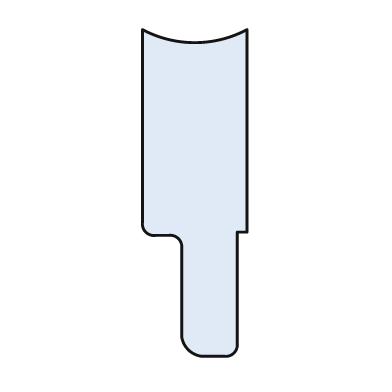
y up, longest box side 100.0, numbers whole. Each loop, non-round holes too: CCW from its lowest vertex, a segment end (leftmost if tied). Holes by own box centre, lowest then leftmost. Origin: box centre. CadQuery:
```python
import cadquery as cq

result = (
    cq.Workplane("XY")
    .moveTo(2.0, -50.0)
    .lineTo(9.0, -50.0)
    .threePointArc((12.0, -49.0), (13.0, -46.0))
    .lineTo(13.0, -12.0)
    .lineTo(16.0, -12.0)
    .lineTo(16.0, 50.0)
    .threePointArc((0.0, 46.0), (-16.0, 50.0))
    .lineTo(-16.0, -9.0)
    .threePointArc((-15.0, -12.0), (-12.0, -13.0))
    .lineTo(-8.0, -13.0)
    .threePointArc((-5.0, -14.0), (-4.0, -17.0))
    .lineTo(-4.0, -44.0)
    .threePointArc((-2.0, -48.0), (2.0, -50.0))
    .close()
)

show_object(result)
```